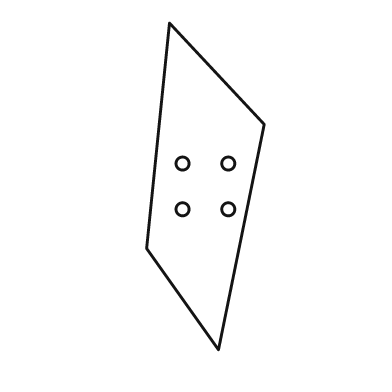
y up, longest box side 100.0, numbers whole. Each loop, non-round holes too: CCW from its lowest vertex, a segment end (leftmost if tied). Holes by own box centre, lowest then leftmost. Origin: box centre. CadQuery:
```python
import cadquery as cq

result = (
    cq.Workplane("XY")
    .moveTo(4.0, -50.0)
    .lineTo(18.0, 19.0)
    .lineTo(-11.0, 50.0)
    .lineTo(-18.0, -19.0)
    .close()
    .moveTo(-7.0, -7.0)
    .circle(2.0)
    .moveTo(7.0, -7.0)
    .circle(2.0)
    .moveTo(-7.0, 7.0)
    .circle(2.0)
    .moveTo(7.0, 7.0)
    .circle(2.0)
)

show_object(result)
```